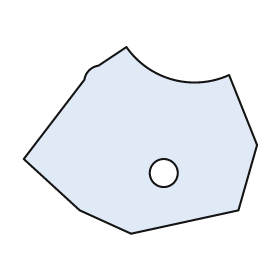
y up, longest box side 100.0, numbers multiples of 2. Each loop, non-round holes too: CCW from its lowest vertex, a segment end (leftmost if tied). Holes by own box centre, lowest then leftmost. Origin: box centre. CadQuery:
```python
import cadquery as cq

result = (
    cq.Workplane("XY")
    .moveTo(-4.0, -40.0)
    .lineTo(42.0, -30.0)
    .lineTo(50.0, -2.0)
    .lineTo(38.0, 28.0)
    .threePointArc((14.0, 26.0), (-6.0, 40.0))
    .lineTo(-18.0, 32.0)
    .threePointArc((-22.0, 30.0), (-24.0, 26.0))
    .lineTo(-50.0, -8.0)
    .lineTo(-26.0, -30.0)
    .close()
    .moveTo(10.0, -14.0)
    .circle(6.0)
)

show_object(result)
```